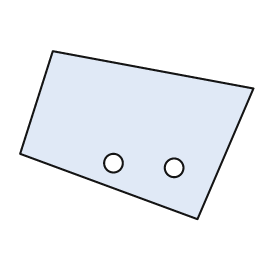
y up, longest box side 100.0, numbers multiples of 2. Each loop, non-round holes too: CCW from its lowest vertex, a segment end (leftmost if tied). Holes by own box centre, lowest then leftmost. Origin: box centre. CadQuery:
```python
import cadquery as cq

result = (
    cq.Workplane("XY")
    .moveTo(26.0, -36.0)
    .lineTo(50.0, 20.0)
    .lineTo(-36.0, 36.0)
    .lineTo(-50.0, -8.0)
    .close()
    .moveTo(16.0, -14.0)
    .circle(4.0)
    .moveTo(-10.0, -12.0)
    .circle(4.0)
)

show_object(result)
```